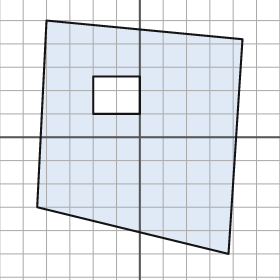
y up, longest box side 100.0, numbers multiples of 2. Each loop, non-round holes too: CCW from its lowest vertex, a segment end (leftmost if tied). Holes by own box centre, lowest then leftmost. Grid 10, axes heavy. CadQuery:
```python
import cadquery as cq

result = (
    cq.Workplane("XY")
    .moveTo(38.0, -50.0)
    .lineTo(44.0, 42.0)
    .lineTo(-40.0, 50.0)
    .lineTo(-44.0, -30.0)
    .close()
    .moveTo(-20.0, 10.0)
    .lineTo(0.0, 10.0)
    .lineTo(0.0, 26.0)
    .lineTo(-20.0, 26.0)
    .close()
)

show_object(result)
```